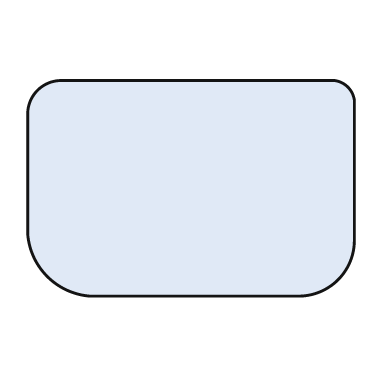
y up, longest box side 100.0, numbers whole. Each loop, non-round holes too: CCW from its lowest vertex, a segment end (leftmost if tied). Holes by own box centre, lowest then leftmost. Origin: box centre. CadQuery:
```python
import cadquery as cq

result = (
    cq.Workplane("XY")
    .moveTo(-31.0, -33.0)
    .lineTo(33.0, -33.0)
    .threePointArc((45.0, -28.0), (50.0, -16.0))
    .lineTo(50.0, 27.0)
    .threePointArc((48.0, 31.0), (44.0, 33.0))
    .lineTo(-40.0, 33.0)
    .threePointArc((-47.0, 30.0), (-50.0, 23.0))
    .lineTo(-50.0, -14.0)
    .threePointArc((-44.0, -27.0), (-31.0, -33.0))
    .close()
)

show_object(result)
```